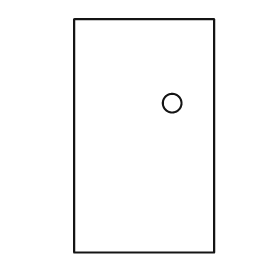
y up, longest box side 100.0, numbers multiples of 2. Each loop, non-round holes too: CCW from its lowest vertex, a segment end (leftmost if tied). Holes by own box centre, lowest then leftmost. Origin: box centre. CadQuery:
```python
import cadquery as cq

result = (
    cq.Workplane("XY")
    .moveTo(-30.0, -50.0)
    .lineTo(30.0, -50.0)
    .lineTo(30.0, 50.0)
    .lineTo(-30.0, 50.0)
    .close()
    .moveTo(12.0, 14.0)
    .circle(4.0)
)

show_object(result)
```